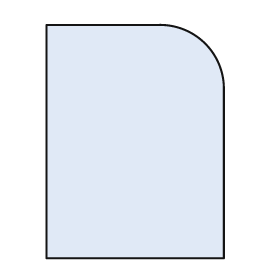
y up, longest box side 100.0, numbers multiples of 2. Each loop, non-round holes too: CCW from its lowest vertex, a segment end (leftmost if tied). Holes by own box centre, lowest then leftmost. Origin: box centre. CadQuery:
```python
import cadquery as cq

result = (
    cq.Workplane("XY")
    .moveTo(-38.0, -50.0)
    .lineTo(38.0, -50.0)
    .lineTo(38.0, 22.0)
    .threePointArc((30.0, 42.0), (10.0, 50.0))
    .lineTo(-38.0, 50.0)
    .close()
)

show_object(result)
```